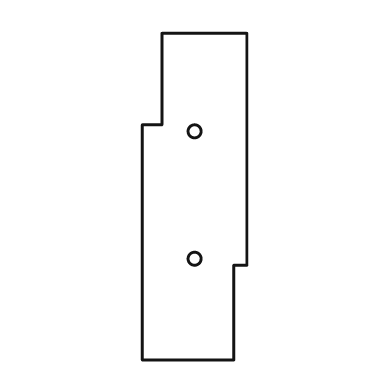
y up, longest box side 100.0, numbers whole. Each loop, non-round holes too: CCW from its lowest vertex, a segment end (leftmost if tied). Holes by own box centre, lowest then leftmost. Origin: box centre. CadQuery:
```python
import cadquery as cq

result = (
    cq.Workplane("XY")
    .moveTo(-16.0, -50.0)
    .lineTo(12.0, -50.0)
    .lineTo(12.0, -21.0)
    .lineTo(16.0, -21.0)
    .lineTo(16.0, 50.0)
    .lineTo(-10.0, 50.0)
    .lineTo(-10.0, 22.0)
    .lineTo(-16.0, 22.0)
    .close()
    .moveTo(0.0, -19.0)
    .circle(2.0)
    .moveTo(0.0, 20.0)
    .circle(2.0)
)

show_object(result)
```